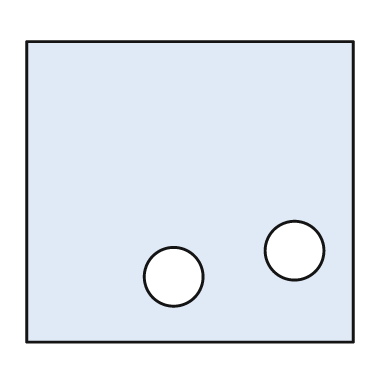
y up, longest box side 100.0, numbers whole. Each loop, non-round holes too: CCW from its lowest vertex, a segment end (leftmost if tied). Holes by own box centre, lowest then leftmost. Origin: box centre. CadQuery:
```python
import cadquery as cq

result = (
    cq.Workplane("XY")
    .moveTo(-50.0, -46.0)
    .lineTo(50.0, -46.0)
    .lineTo(50.0, 46.0)
    .lineTo(-50.0, 46.0)
    .close()
    .moveTo(-5.0, -26.0)
    .circle(9.0)
    .moveTo(32.0, -18.0)
    .circle(9.0)
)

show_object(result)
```